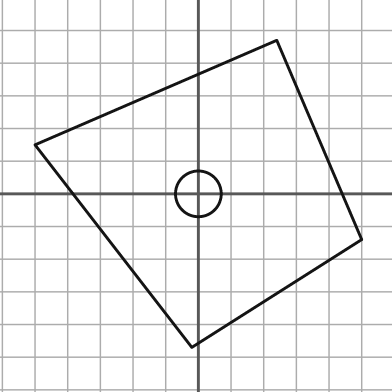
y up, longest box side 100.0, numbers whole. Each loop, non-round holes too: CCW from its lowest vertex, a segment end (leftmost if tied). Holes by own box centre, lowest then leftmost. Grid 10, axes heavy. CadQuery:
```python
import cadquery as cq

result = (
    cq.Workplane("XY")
    .moveTo(-2.0, -47.0)
    .lineTo(50.0, -14.0)
    .lineTo(24.0, 47.0)
    .lineTo(-50.0, 15.0)
    .close()
    .moveTo(0.0, 0.0)
    .circle(7.0)
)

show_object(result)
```